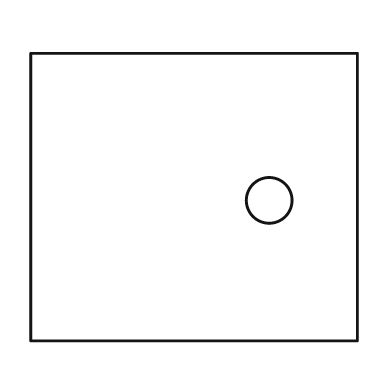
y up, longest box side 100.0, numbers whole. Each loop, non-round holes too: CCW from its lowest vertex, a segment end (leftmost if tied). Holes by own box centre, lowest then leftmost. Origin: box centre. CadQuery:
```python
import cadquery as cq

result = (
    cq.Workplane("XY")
    .moveTo(-50.0, -44.0)
    .lineTo(50.0, -44.0)
    .lineTo(50.0, 44.0)
    .lineTo(-50.0, 44.0)
    .close()
    .moveTo(23.0, -1.0)
    .circle(7.0)
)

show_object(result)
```